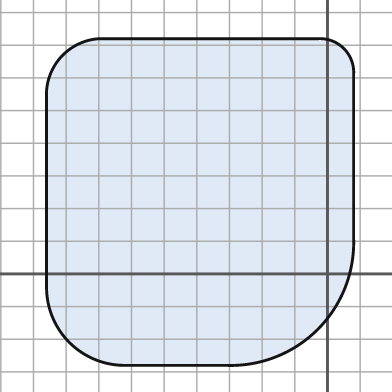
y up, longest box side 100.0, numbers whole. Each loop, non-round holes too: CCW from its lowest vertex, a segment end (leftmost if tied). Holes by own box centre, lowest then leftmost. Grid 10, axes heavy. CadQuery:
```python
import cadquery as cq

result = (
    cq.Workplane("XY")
    .moveTo(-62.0, -28.0)
    .lineTo(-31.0, -28.0)
    .threePointArc((-3.0, -17.0), (8.0, 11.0))
    .lineTo(8.0, 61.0)
    .threePointArc((5.0, 69.0), (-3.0, 72.0))
    .lineTo(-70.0, 72.0)
    .threePointArc((-81.0, 67.0), (-86.0, 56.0))
    .lineTo(-86.0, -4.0)
    .threePointArc((-79.0, -21.0), (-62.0, -28.0))
    .close()
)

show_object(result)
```